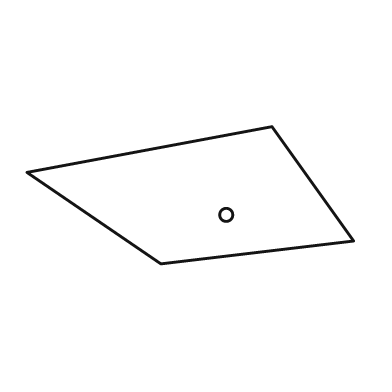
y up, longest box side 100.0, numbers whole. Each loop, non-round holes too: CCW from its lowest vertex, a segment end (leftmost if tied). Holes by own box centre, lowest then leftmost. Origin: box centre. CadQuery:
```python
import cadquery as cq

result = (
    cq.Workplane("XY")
    .moveTo(-9.0, -21.0)
    .lineTo(50.0, -14.0)
    .lineTo(25.0, 21.0)
    .lineTo(-50.0, 7.0)
    .close()
    .moveTo(11.0, -6.0)
    .circle(2.0)
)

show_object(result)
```